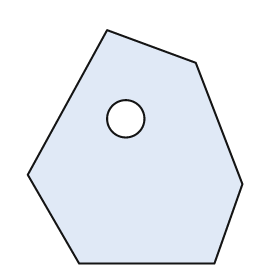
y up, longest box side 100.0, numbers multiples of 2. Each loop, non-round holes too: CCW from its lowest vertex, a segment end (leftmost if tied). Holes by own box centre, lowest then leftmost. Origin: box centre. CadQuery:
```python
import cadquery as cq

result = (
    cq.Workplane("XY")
    .moveTo(-24.0, -50.0)
    .lineTo(34.0, -50.0)
    .lineTo(46.0, -16.0)
    .lineTo(26.0, 36.0)
    .lineTo(-12.0, 50.0)
    .lineTo(-46.0, -12.0)
    .close()
    .moveTo(-4.0, 12.0)
    .circle(8.0)
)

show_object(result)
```